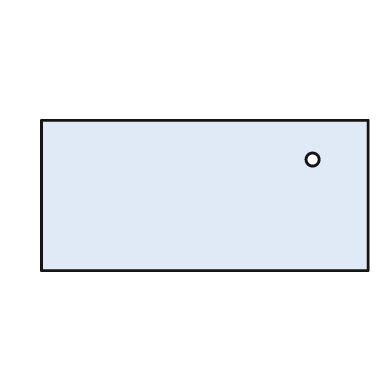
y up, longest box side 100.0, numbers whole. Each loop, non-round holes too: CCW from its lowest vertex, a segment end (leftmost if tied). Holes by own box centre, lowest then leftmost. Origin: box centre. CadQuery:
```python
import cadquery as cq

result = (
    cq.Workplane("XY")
    .moveTo(-50.0, -23.0)
    .lineTo(50.0, -23.0)
    .lineTo(50.0, 23.0)
    .lineTo(-50.0, 23.0)
    .close()
    .moveTo(33.0, 11.0)
    .circle(2.0)
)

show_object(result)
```